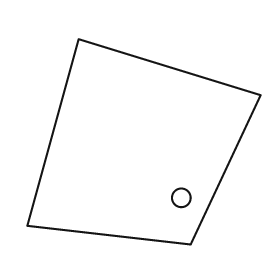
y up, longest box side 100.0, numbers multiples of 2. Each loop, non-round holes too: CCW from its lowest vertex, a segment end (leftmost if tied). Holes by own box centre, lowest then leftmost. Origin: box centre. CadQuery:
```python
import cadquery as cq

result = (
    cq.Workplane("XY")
    .moveTo(20.0, -44.0)
    .lineTo(50.0, 20.0)
    .lineTo(-28.0, 44.0)
    .lineTo(-50.0, -36.0)
    .close()
    .moveTo(16.0, -24.0)
    .circle(4.0)
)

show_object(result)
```